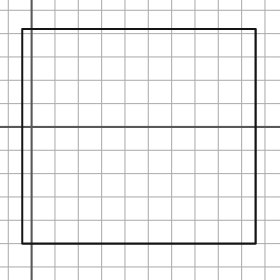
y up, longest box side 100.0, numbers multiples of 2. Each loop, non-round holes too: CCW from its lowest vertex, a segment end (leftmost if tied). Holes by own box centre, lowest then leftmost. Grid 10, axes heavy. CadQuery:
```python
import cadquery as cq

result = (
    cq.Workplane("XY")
    .moveTo(-4.0, -50.0)
    .lineTo(96.0, -50.0)
    .lineTo(96.0, 42.0)
    .lineTo(-4.0, 42.0)
    .close()
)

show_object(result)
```